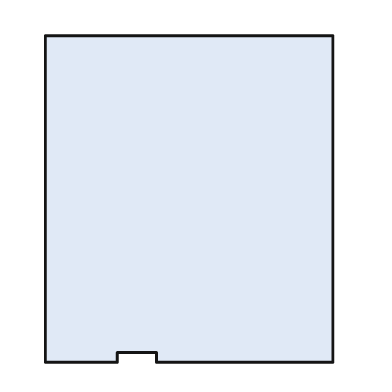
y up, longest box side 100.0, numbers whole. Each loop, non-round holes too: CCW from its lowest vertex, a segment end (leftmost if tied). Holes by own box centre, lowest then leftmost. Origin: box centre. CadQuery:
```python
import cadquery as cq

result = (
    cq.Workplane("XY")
    .moveTo(-44.0, -50.0)
    .lineTo(-22.0, -50.0)
    .lineTo(-22.0, -47.0)
    .lineTo(-10.0, -47.0)
    .lineTo(-10.0, -50.0)
    .lineTo(44.0, -50.0)
    .lineTo(44.0, 50.0)
    .lineTo(-44.0, 50.0)
    .close()
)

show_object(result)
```